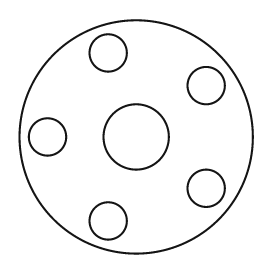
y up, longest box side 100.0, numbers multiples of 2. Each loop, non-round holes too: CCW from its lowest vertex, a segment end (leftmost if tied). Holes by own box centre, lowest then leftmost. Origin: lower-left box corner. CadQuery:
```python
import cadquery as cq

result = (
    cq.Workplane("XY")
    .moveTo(50.0, 50.0)
    .circle(50.0)
    .moveTo(38.0, 14.0)
    .circle(8.0)
    .moveTo(80.0, 28.0)
    .circle(8.0)
    .moveTo(12.0, 50.0)
    .circle(8.0)
    .moveTo(50.0, 50.0)
    .circle(14.0)
    .moveTo(80.0, 72.0)
    .circle(8.0)
    .moveTo(38.0, 86.0)
    .circle(8.0)
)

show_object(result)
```